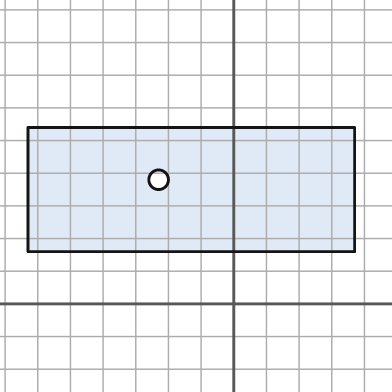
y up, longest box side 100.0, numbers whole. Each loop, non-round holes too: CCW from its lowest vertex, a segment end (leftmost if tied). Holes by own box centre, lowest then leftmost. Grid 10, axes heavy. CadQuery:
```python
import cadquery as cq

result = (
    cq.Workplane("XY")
    .moveTo(-63.0, 16.0)
    .lineTo(37.0, 16.0)
    .lineTo(37.0, 54.0)
    .lineTo(-63.0, 54.0)
    .close()
    .moveTo(-23.0, 38.0)
    .circle(3.0)
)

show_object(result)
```